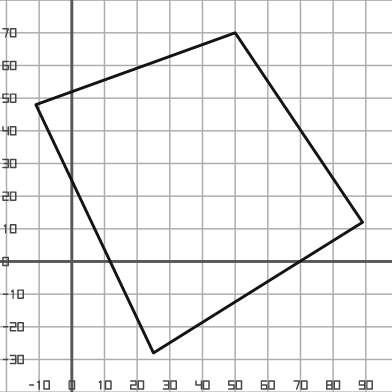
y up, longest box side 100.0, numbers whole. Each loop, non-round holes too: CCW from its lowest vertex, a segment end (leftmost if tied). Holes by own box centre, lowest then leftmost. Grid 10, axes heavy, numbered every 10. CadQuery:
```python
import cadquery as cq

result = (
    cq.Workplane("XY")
    .moveTo(25.0, -28.0)
    .lineTo(89.0, 12.0)
    .lineTo(50.0, 70.0)
    .lineTo(-11.0, 48.0)
    .close()
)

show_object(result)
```